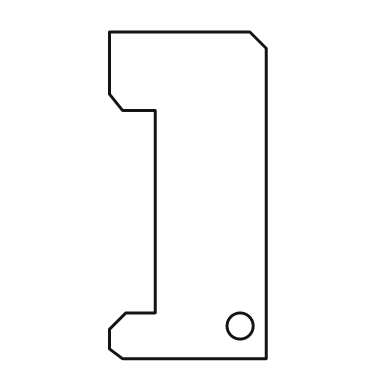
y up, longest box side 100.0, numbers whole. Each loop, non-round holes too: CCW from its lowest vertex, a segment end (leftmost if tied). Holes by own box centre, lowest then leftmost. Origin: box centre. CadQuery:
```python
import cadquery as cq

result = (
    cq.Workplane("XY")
    .moveTo(-20.0, -50.0)
    .lineTo(24.0, -50.0)
    .lineTo(24.0, 45.0)
    .lineTo(19.0, 50.0)
    .lineTo(-24.0, 50.0)
    .lineTo(-24.0, 31.0)
    .lineTo(-20.0, 26.0)
    .lineTo(-10.0, 26.0)
    .lineTo(-10.0, -36.0)
    .lineTo(-19.0, -36.0)
    .lineTo(-24.0, -41.0)
    .lineTo(-24.0, -47.0)
    .close()
    .moveTo(16.0, -40.0)
    .circle(4.0)
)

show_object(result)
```